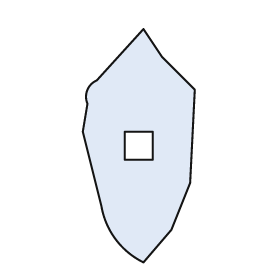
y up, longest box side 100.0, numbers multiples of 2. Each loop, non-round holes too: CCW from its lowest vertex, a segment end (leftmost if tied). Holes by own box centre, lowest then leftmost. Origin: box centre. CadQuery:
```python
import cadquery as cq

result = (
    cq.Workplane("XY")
    .moveTo(2.0, -50.0)
    .lineTo(14.0, -36.0)
    .lineTo(22.0, -16.0)
    .lineTo(24.0, 24.0)
    .lineTo(10.0, 38.0)
    .lineTo(2.0, 50.0)
    .lineTo(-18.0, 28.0)
    .threePointArc((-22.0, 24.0), (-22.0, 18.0))
    .lineTo(-24.0, 6.0)
    .lineTo(-16.0, -26.0)
    .threePointArc((-10.0, -40.0), (2.0, -50.0))
    .close()
    .moveTo(-6.0, -6.0)
    .lineTo(6.0, -6.0)
    .lineTo(6.0, 6.0)
    .lineTo(-6.0, 6.0)
    .close()
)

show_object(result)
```